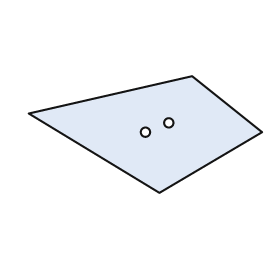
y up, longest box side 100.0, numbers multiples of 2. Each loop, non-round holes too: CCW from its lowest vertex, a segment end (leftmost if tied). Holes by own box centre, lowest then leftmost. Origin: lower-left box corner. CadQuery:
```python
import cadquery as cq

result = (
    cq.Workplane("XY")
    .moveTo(56.0, 0.0)
    .lineTo(100.0, 26.0)
    .lineTo(70.0, 50.0)
    .lineTo(0.0, 34.0)
    .close()
    .moveTo(50.0, 26.0)
    .circle(2.0)
    .moveTo(60.0, 30.0)
    .circle(2.0)
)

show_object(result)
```